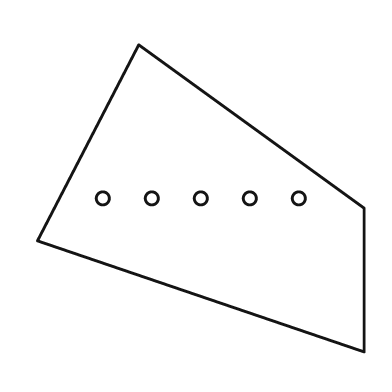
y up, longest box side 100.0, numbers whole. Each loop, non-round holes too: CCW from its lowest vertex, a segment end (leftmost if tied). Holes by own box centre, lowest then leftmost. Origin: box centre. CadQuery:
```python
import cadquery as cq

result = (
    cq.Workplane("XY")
    .moveTo(50.0, -47.0)
    .lineTo(50.0, -3.0)
    .lineTo(-19.0, 47.0)
    .lineTo(-50.0, -13.0)
    .close()
    .moveTo(-30.0, 0.0)
    .circle(2.0)
    .moveTo(-15.0, 0.0)
    .circle(2.0)
    .moveTo(0.0, 0.0)
    .circle(2.0)
    .moveTo(15.0, 0.0)
    .circle(2.0)
    .moveTo(30.0, 0.0)
    .circle(2.0)
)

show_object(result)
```